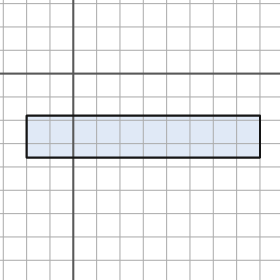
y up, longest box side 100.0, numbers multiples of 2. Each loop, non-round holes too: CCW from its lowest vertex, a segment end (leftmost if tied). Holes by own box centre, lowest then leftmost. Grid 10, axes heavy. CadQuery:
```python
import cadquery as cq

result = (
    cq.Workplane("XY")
    .moveTo(-20.0, -36.0)
    .lineTo(80.0, -36.0)
    .lineTo(80.0, -18.0)
    .lineTo(-20.0, -18.0)
    .close()
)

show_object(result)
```